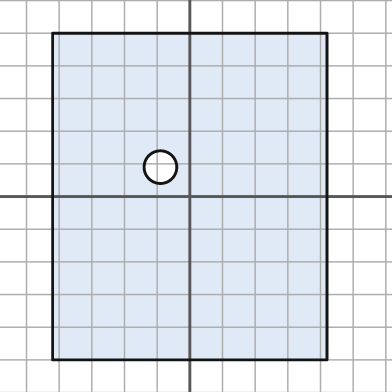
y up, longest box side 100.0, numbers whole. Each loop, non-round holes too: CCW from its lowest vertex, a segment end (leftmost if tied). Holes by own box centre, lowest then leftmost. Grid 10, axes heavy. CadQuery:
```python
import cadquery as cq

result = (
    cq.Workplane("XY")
    .moveTo(-42.0, -50.0)
    .lineTo(42.0, -50.0)
    .lineTo(42.0, 50.0)
    .lineTo(-42.0, 50.0)
    .close()
    .moveTo(-9.0, 9.0)
    .circle(5.0)
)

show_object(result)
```